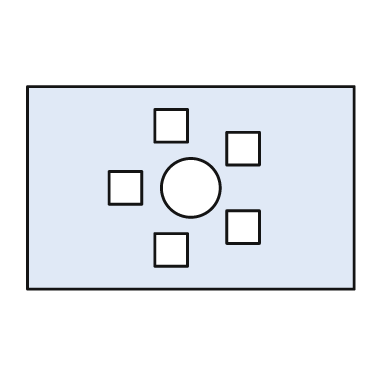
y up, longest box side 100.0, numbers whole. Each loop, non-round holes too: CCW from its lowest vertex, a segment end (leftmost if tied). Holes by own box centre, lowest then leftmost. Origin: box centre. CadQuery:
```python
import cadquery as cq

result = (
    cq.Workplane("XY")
    .moveTo(-50.0, -31.0)
    .lineTo(50.0, -31.0)
    .lineTo(50.0, 31.0)
    .lineTo(-50.0, 31.0)
    .close()
    .moveTo(-11.0, -24.0)
    .lineTo(-1.0, -24.0)
    .lineTo(-1.0, -14.0)
    .lineTo(-11.0, -14.0)
    .close()
    .moveTo(11.0, -17.0)
    .lineTo(21.0, -17.0)
    .lineTo(21.0, -7.0)
    .lineTo(11.0, -7.0)
    .close()
    .moveTo(-25.0, -5.0)
    .lineTo(-15.0, -5.0)
    .lineTo(-15.0, 5.0)
    .lineTo(-25.0, 5.0)
    .close()
    .moveTo(0.0, 0.0)
    .circle(9.0)
    .moveTo(11.0, 7.0)
    .lineTo(21.0, 7.0)
    .lineTo(21.0, 17.0)
    .lineTo(11.0, 17.0)
    .close()
    .moveTo(-11.0, 14.0)
    .lineTo(-1.0, 14.0)
    .lineTo(-1.0, 24.0)
    .lineTo(-11.0, 24.0)
    .close()
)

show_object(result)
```